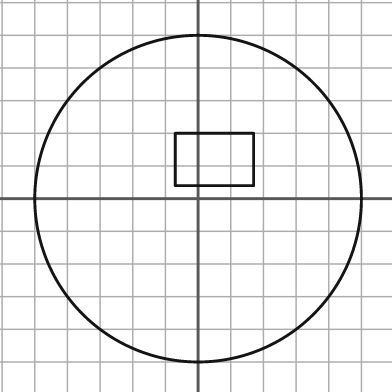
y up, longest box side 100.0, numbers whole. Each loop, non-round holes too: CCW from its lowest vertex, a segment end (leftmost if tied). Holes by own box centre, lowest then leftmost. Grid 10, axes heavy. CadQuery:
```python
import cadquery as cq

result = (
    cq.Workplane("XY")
    .moveTo(0.0, 0.0)
    .circle(50.0)
    .moveTo(-7.0, 4.0)
    .lineTo(17.0, 4.0)
    .lineTo(17.0, 20.0)
    .lineTo(-7.0, 20.0)
    .close()
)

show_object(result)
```